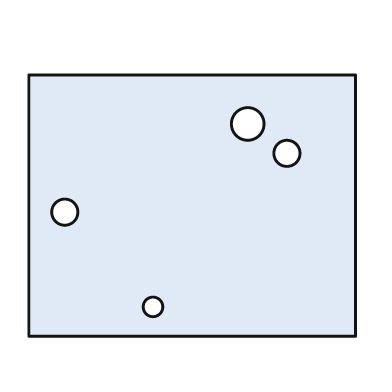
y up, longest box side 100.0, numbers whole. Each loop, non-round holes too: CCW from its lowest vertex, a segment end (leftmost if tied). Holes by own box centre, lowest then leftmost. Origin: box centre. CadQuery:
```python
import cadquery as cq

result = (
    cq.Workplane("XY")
    .moveTo(-50.0, -40.0)
    .lineTo(50.0, -40.0)
    .lineTo(50.0, 40.0)
    .lineTo(-50.0, 40.0)
    .close()
    .moveTo(-12.0, -31.0)
    .circle(3.0)
    .moveTo(-39.0, -2.0)
    .circle(4.0)
    .moveTo(29.0, 16.0)
    .circle(4.0)
    .moveTo(17.0, 25.0)
    .circle(5.0)
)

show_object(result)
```